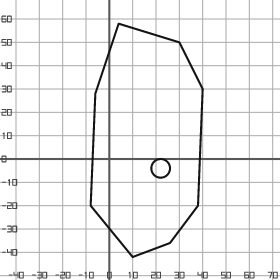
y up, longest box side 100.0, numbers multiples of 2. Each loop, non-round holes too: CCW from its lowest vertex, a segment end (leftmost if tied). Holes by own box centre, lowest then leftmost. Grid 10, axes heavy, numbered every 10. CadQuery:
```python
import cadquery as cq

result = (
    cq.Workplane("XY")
    .moveTo(10.0, -42.0)
    .lineTo(26.0, -36.0)
    .lineTo(38.0, -20.0)
    .lineTo(40.0, 30.0)
    .lineTo(30.0, 50.0)
    .lineTo(4.0, 58.0)
    .lineTo(-6.0, 28.0)
    .lineTo(-8.0, -20.0)
    .close()
    .moveTo(22.0, -4.0)
    .circle(4.0)
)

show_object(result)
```